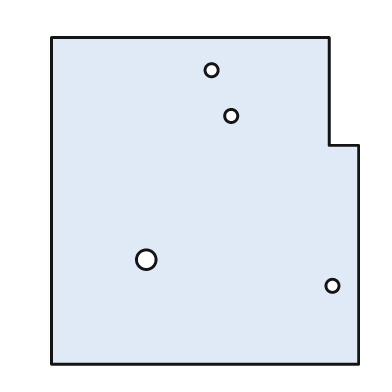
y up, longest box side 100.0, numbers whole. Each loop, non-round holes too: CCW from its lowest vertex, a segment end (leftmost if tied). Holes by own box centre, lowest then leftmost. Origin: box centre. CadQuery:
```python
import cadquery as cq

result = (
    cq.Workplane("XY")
    .moveTo(-47.0, -50.0)
    .lineTo(47.0, -50.0)
    .lineTo(47.0, 17.0)
    .lineTo(38.0, 17.0)
    .lineTo(38.0, 50.0)
    .lineTo(-47.0, 50.0)
    .close()
    .moveTo(39.0, -26.0)
    .circle(2.0)
    .moveTo(-18.0, -18.0)
    .circle(3.0)
    .moveTo(8.0, 26.0)
    .circle(2.0)
    .moveTo(2.0, 40.0)
    .circle(2.0)
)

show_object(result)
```